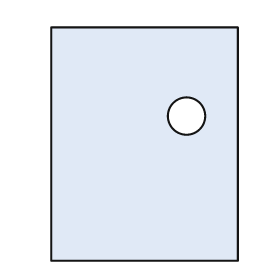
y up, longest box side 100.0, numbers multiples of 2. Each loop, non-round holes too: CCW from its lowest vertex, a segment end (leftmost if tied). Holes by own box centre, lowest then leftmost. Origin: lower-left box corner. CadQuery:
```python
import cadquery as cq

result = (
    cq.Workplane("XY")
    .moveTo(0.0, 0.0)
    .lineTo(80.0, 0.0)
    .lineTo(80.0, 100.0)
    .lineTo(0.0, 100.0)
    .close()
    .moveTo(58.0, 62.0)
    .circle(8.0)
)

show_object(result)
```